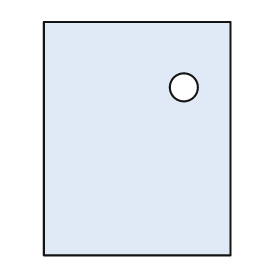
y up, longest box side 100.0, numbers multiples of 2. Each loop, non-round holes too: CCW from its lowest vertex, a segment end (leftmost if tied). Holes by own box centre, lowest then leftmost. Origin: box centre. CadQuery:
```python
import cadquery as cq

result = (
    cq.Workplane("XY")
    .moveTo(-40.0, -50.0)
    .lineTo(40.0, -50.0)
    .lineTo(40.0, 50.0)
    .lineTo(-40.0, 50.0)
    .close()
    .moveTo(20.0, 22.0)
    .circle(6.0)
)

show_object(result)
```